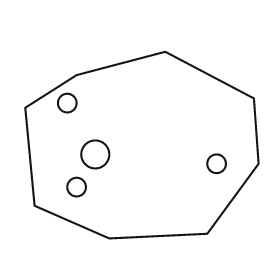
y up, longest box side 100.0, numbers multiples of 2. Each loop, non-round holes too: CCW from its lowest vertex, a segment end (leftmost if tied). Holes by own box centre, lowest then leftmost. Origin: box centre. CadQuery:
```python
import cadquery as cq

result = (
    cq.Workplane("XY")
    .moveTo(-14.0, -40.0)
    .lineTo(28.0, -38.0)
    .lineTo(50.0, -8.0)
    .lineTo(48.0, 20.0)
    .lineTo(10.0, 40.0)
    .lineTo(-28.0, 30.0)
    .lineTo(-50.0, 16.0)
    .lineTo(-46.0, -26.0)
    .close()
    .moveTo(-28.0, -18.0)
    .circle(4.0)
    .moveTo(32.0, -8.0)
    .circle(4.0)
    .moveTo(-20.0, -4.0)
    .circle(6.0)
    .moveTo(-32.0, 18.0)
    .circle(4.0)
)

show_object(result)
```